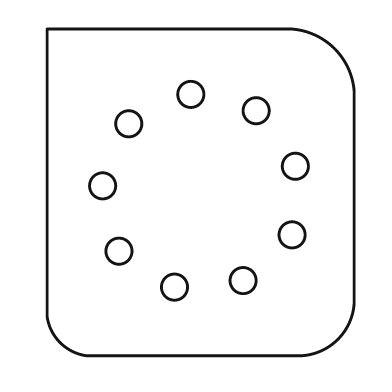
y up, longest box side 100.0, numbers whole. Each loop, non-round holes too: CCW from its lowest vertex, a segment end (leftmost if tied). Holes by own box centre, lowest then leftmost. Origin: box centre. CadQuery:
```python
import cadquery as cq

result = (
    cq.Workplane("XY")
    .moveTo(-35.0, -50.0)
    .lineTo(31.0, -50.0)
    .threePointArc((42.0, -45.0), (47.0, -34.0))
    .lineTo(47.0, 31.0)
    .threePointArc((41.0, 44.0), (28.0, 50.0))
    .lineTo(-47.0, 50.0)
    .lineTo(-47.0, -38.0)
    .threePointArc((-43.0, -46.0), (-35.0, -50.0))
    .close()
    .moveTo(-8.0, -29.0)
    .circle(4.0)
    .moveTo(13.0, -27.0)
    .circle(4.0)
    .moveTo(-25.0, -18.0)
    .circle(4.0)
    .moveTo(28.0, -13.0)
    .circle(4.0)
    .moveTo(-30.0, 2.0)
    .circle(4.0)
    .moveTo(29.0, 8.0)
    .circle(4.0)
    .moveTo(-22.0, 21.0)
    .circle(4.0)
    .moveTo(17.0, 25.0)
    .circle(4.0)
    .moveTo(-3.0, 30.0)
    .circle(4.0)
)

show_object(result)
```